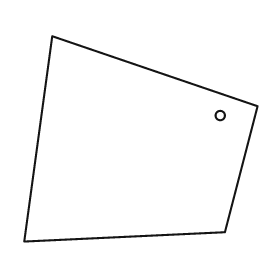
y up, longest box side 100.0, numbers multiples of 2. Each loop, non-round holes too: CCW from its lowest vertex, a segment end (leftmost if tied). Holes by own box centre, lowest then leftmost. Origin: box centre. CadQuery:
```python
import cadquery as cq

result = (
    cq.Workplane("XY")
    .moveTo(-50.0, -44.0)
    .lineTo(36.0, -40.0)
    .lineTo(50.0, 14.0)
    .lineTo(-38.0, 44.0)
    .close()
    .moveTo(34.0, 10.0)
    .circle(2.0)
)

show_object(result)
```